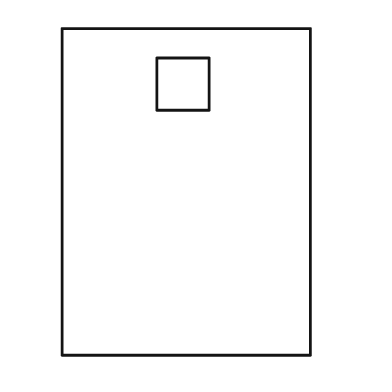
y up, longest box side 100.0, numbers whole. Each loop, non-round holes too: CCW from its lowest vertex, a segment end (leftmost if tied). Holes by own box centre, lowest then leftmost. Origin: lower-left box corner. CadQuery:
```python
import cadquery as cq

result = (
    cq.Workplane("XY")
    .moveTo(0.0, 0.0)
    .lineTo(76.0, 0.0)
    .lineTo(76.0, 100.0)
    .lineTo(0.0, 100.0)
    .close()
    .moveTo(29.0, 75.0)
    .lineTo(45.0, 75.0)
    .lineTo(45.0, 91.0)
    .lineTo(29.0, 91.0)
    .close()
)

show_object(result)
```